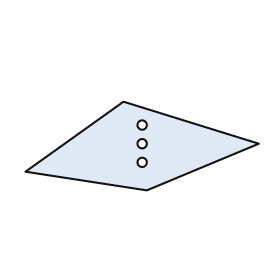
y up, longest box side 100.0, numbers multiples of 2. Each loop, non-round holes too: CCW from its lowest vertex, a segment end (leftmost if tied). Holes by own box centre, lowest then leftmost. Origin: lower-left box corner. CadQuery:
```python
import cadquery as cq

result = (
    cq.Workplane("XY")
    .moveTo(52.0, 0.0)
    .lineTo(100.0, 20.0)
    .lineTo(42.0, 38.0)
    .lineTo(0.0, 8.0)
    .close()
    .moveTo(50.0, 12.0)
    .circle(2.0)
    .moveTo(50.0, 20.0)
    .circle(2.0)
    .moveTo(50.0, 28.0)
    .circle(2.0)
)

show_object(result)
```